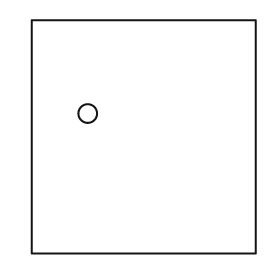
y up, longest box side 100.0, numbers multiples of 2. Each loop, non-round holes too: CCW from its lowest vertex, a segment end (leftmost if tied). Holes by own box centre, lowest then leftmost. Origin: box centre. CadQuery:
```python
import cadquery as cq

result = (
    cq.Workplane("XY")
    .moveTo(-48.0, -50.0)
    .lineTo(48.0, -50.0)
    .lineTo(48.0, 50.0)
    .lineTo(-48.0, 50.0)
    .close()
    .moveTo(-24.0, 10.0)
    .circle(4.0)
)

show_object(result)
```